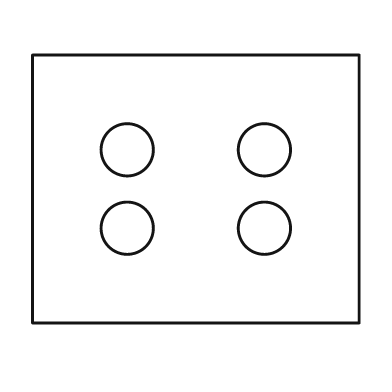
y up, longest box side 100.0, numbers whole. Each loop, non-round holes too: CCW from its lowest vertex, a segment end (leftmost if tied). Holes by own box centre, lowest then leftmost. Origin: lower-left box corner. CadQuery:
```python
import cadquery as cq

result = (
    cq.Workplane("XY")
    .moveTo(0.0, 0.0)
    .lineTo(100.0, 0.0)
    .lineTo(100.0, 82.0)
    .lineTo(0.0, 82.0)
    .close()
    .moveTo(29.0, 29.0)
    .circle(8.0)
    .moveTo(71.0, 29.0)
    .circle(8.0)
    .moveTo(29.0, 53.0)
    .circle(8.0)
    .moveTo(71.0, 53.0)
    .circle(8.0)
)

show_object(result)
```